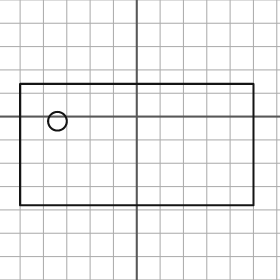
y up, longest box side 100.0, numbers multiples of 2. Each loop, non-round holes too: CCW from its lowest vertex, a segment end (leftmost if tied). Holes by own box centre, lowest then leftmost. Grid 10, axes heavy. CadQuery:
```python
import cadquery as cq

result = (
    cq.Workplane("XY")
    .moveTo(-50.0, -38.0)
    .lineTo(50.0, -38.0)
    .lineTo(50.0, 14.0)
    .lineTo(-50.0, 14.0)
    .close()
    .moveTo(-34.0, -2.0)
    .circle(4.0)
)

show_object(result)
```